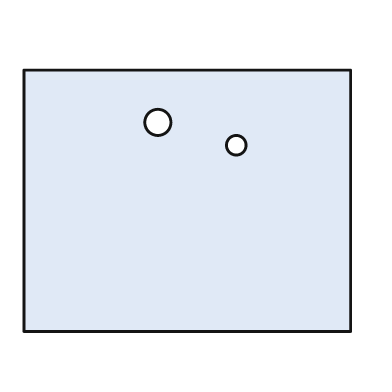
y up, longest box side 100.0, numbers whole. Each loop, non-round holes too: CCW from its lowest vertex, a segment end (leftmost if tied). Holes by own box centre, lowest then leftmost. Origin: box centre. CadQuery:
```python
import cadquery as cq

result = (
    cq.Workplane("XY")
    .moveTo(-50.0, -40.0)
    .lineTo(50.0, -40.0)
    .lineTo(50.0, 40.0)
    .lineTo(-50.0, 40.0)
    .close()
    .moveTo(15.0, 17.0)
    .circle(3.0)
    .moveTo(-9.0, 24.0)
    .circle(4.0)
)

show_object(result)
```